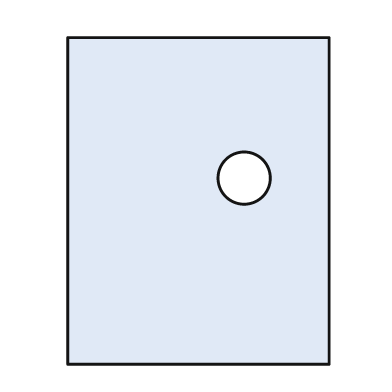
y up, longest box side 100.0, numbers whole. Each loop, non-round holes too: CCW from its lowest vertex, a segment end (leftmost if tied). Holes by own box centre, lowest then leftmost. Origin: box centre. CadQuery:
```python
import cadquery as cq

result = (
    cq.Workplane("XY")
    .moveTo(-40.0, -50.0)
    .lineTo(40.0, -50.0)
    .lineTo(40.0, 50.0)
    .lineTo(-40.0, 50.0)
    .close()
    .moveTo(14.0, 7.0)
    .circle(8.0)
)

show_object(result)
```